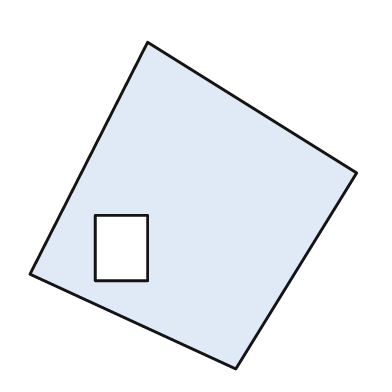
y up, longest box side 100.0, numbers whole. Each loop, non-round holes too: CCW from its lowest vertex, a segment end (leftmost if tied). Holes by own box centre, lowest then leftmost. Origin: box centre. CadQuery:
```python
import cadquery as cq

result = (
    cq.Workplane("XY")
    .moveTo(13.0, -50.0)
    .lineTo(50.0, 10.0)
    .lineTo(-14.0, 50.0)
    .lineTo(-50.0, -21.0)
    .close()
    .moveTo(-30.0, -23.0)
    .lineTo(-14.0, -23.0)
    .lineTo(-14.0, -3.0)
    .lineTo(-30.0, -3.0)
    .close()
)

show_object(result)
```